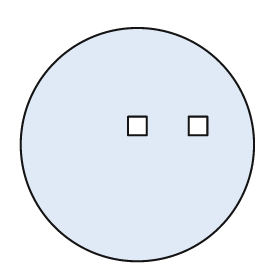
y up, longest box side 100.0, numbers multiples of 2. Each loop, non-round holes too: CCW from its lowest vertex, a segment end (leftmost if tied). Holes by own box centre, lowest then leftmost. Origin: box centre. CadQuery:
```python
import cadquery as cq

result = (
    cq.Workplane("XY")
    .moveTo(0.0, 0.0)
    .circle(50.0)
    .moveTo(-4.0, 4.0)
    .lineTo(4.0, 4.0)
    .lineTo(4.0, 12.0)
    .lineTo(-4.0, 12.0)
    .close()
    .moveTo(22.0, 4.0)
    .lineTo(30.0, 4.0)
    .lineTo(30.0, 12.0)
    .lineTo(22.0, 12.0)
    .close()
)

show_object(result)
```